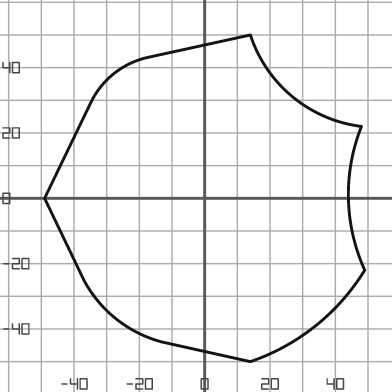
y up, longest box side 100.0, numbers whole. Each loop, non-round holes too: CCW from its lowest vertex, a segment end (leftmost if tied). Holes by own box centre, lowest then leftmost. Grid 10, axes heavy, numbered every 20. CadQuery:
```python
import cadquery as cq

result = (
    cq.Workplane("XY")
    .moveTo(14.0, -50.0)
    .threePointArc((34.0, -39.0), (49.0, -22.0))
    .threePointArc((44.0, 0.0), (48.0, 22.0))
    .threePointArc((27.0, 31.0), (14.0, 50.0))
    .lineTo(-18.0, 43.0)
    .threePointArc((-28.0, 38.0), (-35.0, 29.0))
    .lineTo(-49.0, 0.0)
    .lineTo(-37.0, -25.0)
    .threePointArc((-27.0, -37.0), (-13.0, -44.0))
    .close()
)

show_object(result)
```